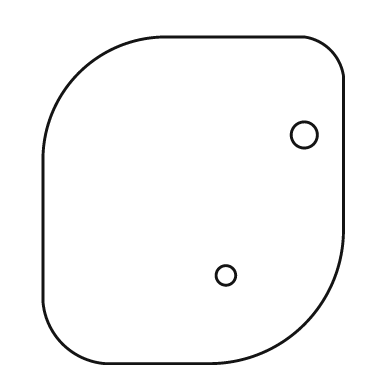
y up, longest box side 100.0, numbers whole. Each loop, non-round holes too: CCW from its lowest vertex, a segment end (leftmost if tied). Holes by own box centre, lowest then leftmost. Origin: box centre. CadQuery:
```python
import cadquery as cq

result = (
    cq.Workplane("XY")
    .moveTo(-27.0, -50.0)
    .lineTo(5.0, -50.0)
    .threePointArc((34.0, -38.0), (46.0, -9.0))
    .lineTo(46.0, 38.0)
    .threePointArc((42.0, 46.0), (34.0, 50.0))
    .lineTo(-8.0, 50.0)
    .threePointArc((-35.0, 39.0), (-46.0, 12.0))
    .lineTo(-46.0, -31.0)
    .threePointArc((-40.0, -44.0), (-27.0, -50.0))
    .close()
    .moveTo(10.0, -23.0)
    .circle(3.0)
    .moveTo(34.0, 20.0)
    .circle(4.0)
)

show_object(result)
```